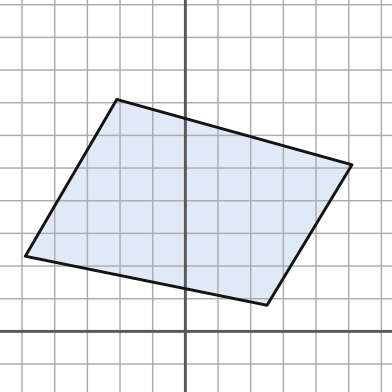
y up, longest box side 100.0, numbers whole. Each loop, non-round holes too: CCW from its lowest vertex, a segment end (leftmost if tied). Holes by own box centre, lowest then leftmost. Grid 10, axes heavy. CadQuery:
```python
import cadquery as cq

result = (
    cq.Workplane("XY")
    .moveTo(25.0, 8.0)
    .lineTo(51.0, 51.0)
    .lineTo(-21.0, 71.0)
    .lineTo(-49.0, 23.0)
    .close()
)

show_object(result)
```